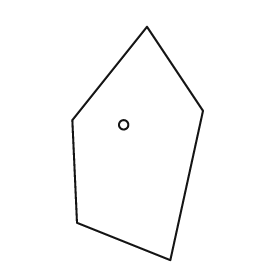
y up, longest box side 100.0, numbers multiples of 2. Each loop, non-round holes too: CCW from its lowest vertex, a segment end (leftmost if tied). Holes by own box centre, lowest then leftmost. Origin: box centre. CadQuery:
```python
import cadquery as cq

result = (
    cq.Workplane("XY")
    .moveTo(14.0, -50.0)
    .lineTo(28.0, 14.0)
    .lineTo(4.0, 50.0)
    .lineTo(-28.0, 10.0)
    .lineTo(-26.0, -34.0)
    .close()
    .moveTo(-6.0, 8.0)
    .circle(2.0)
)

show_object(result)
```